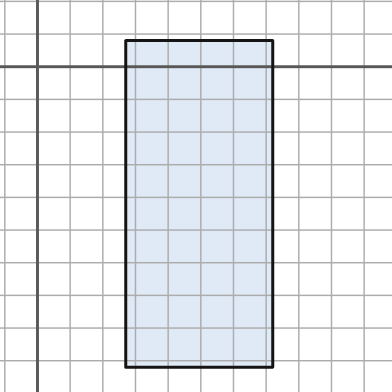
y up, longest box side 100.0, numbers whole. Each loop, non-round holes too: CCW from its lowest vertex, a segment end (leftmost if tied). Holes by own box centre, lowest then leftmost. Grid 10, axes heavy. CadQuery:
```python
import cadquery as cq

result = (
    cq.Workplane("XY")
    .moveTo(27.0, -92.0)
    .lineTo(72.0, -92.0)
    .lineTo(72.0, 8.0)
    .lineTo(27.0, 8.0)
    .close()
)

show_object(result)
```